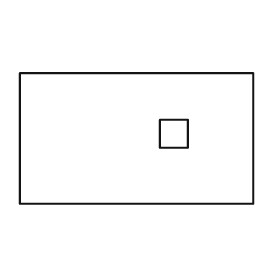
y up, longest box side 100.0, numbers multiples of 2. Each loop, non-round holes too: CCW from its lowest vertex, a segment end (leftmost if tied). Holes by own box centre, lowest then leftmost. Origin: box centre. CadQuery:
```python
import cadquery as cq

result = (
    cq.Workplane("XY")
    .moveTo(-50.0, -28.0)
    .lineTo(50.0, -28.0)
    .lineTo(50.0, 28.0)
    .lineTo(-50.0, 28.0)
    .close()
    .moveTo(10.0, -4.0)
    .lineTo(22.0, -4.0)
    .lineTo(22.0, 8.0)
    .lineTo(10.0, 8.0)
    .close()
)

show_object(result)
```